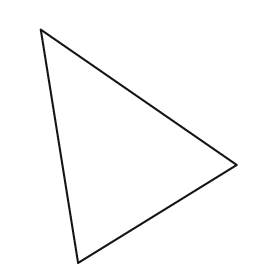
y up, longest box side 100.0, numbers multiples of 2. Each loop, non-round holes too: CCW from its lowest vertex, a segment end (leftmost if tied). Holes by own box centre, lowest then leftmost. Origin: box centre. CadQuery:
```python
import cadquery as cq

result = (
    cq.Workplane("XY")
    .moveTo(-26.0, -50.0)
    .lineTo(42.0, -8.0)
    .lineTo(-42.0, 50.0)
    .close()
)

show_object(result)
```